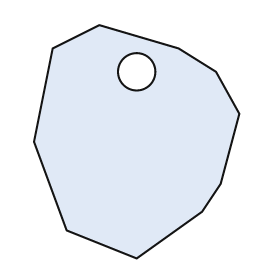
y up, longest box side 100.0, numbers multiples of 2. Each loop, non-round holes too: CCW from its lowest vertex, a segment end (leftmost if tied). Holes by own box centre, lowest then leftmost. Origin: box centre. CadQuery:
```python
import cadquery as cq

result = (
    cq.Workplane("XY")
    .moveTo(0.0, -50.0)
    .lineTo(28.0, -30.0)
    .lineTo(36.0, -18.0)
    .lineTo(44.0, 12.0)
    .lineTo(34.0, 30.0)
    .lineTo(18.0, 40.0)
    .lineTo(-16.0, 50.0)
    .lineTo(-36.0, 40.0)
    .lineTo(-44.0, 0.0)
    .lineTo(-30.0, -38.0)
    .close()
    .moveTo(0.0, 30.0)
    .circle(8.0)
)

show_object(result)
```